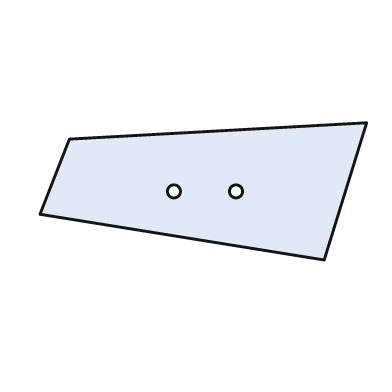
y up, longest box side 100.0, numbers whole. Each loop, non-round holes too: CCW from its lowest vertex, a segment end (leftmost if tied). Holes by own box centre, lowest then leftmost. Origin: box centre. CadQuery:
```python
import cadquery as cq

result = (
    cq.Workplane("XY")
    .moveTo(37.0, -21.0)
    .lineTo(50.0, 21.0)
    .lineTo(-41.0, 16.0)
    .lineTo(-50.0, -7.0)
    .close()
    .moveTo(-9.0, 0.0)
    .circle(2.0)
    .moveTo(10.0, 0.0)
    .circle(2.0)
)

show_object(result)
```